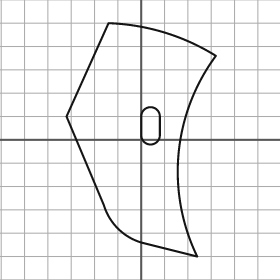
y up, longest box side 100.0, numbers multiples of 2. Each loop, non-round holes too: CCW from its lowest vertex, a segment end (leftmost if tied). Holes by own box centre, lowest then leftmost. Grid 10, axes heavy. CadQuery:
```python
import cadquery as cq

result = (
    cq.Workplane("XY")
    .moveTo(24.0, -50.0)
    .threePointArc((16.0, -6.0), (32.0, 36.0))
    .threePointArc((10.0, 46.0), (-14.0, 50.0))
    .lineTo(-32.0, 10.0)
    .lineTo(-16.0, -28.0)
    .threePointArc((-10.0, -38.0), (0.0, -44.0))
    .close()
    .moveTo(0.0, 2.0)
    .threePointArc((4.0, -2.0), (8.0, 2.0))
    .lineTo(8.0, 10.0)
    .threePointArc((4.0, 14.0), (0.0, 10.0))
    .close()
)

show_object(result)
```